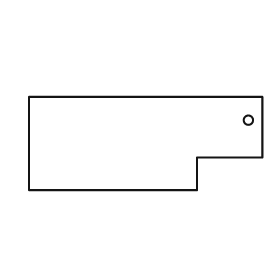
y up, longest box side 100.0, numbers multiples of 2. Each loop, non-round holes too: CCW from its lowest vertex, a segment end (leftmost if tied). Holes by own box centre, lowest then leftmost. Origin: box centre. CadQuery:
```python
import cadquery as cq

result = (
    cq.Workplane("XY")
    .moveTo(-50.0, -20.0)
    .lineTo(22.0, -20.0)
    .lineTo(22.0, -6.0)
    .lineTo(50.0, -6.0)
    .lineTo(50.0, 20.0)
    .lineTo(-50.0, 20.0)
    .close()
    .moveTo(44.0, 10.0)
    .circle(2.0)
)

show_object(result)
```